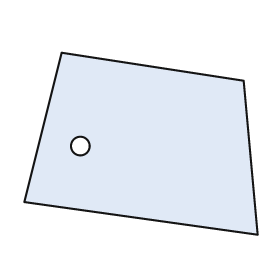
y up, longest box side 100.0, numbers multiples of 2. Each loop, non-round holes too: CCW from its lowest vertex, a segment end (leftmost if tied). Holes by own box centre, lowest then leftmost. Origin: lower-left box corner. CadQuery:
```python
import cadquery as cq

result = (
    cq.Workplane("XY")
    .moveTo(100.0, 0.0)
    .lineTo(94.0, 66.0)
    .lineTo(16.0, 78.0)
    .lineTo(0.0, 14.0)
    .close()
    .moveTo(24.0, 38.0)
    .circle(4.0)
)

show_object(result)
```